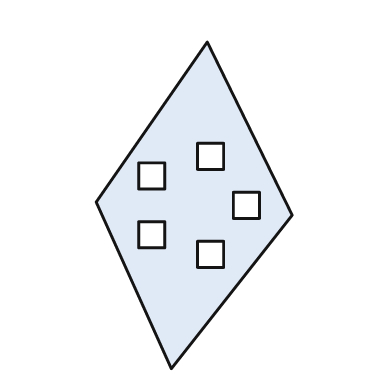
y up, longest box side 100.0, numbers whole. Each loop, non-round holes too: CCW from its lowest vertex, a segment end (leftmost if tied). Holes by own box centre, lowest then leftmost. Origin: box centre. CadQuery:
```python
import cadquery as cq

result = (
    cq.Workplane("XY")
    .moveTo(-7.0, -50.0)
    .lineTo(30.0, -3.0)
    .lineTo(4.0, 50.0)
    .lineTo(-30.0, 1.0)
    .close()
    .moveTo(1.0, -19.0)
    .lineTo(9.0, -19.0)
    .lineTo(9.0, -11.0)
    .lineTo(1.0, -11.0)
    .close()
    .moveTo(-17.0, -13.0)
    .lineTo(-9.0, -13.0)
    .lineTo(-9.0, -5.0)
    .lineTo(-17.0, -5.0)
    .close()
    .moveTo(12.0, -4.0)
    .lineTo(20.0, -4.0)
    .lineTo(20.0, 4.0)
    .lineTo(12.0, 4.0)
    .close()
    .moveTo(-17.0, 5.0)
    .lineTo(-9.0, 5.0)
    .lineTo(-9.0, 13.0)
    .lineTo(-17.0, 13.0)
    .close()
    .moveTo(1.0, 11.0)
    .lineTo(9.0, 11.0)
    .lineTo(9.0, 19.0)
    .lineTo(1.0, 19.0)
    .close()
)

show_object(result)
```